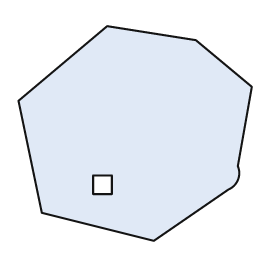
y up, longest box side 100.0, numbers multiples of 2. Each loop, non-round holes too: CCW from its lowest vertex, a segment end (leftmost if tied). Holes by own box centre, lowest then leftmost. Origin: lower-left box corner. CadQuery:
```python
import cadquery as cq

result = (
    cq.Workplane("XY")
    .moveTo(58.0, 0.0)
    .lineTo(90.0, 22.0)
    .threePointArc((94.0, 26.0), (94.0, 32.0))
    .lineTo(100.0, 66.0)
    .lineTo(76.0, 86.0)
    .lineTo(38.0, 92.0)
    .lineTo(0.0, 60.0)
    .lineTo(10.0, 12.0)
    .close()
    .moveTo(32.0, 20.0)
    .lineTo(40.0, 20.0)
    .lineTo(40.0, 28.0)
    .lineTo(32.0, 28.0)
    .close()
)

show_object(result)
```